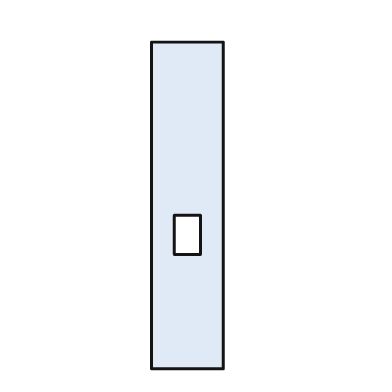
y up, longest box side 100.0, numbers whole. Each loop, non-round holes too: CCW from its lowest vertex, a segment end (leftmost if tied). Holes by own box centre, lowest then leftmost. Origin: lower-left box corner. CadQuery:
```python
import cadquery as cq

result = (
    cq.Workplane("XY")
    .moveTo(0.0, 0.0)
    .lineTo(22.0, 0.0)
    .lineTo(22.0, 100.0)
    .lineTo(0.0, 100.0)
    .close()
    .moveTo(7.0, 35.0)
    .lineTo(15.0, 35.0)
    .lineTo(15.0, 47.0)
    .lineTo(7.0, 47.0)
    .close()
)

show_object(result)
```